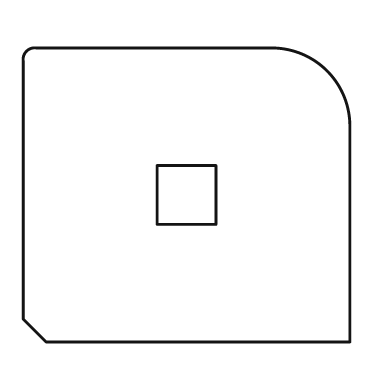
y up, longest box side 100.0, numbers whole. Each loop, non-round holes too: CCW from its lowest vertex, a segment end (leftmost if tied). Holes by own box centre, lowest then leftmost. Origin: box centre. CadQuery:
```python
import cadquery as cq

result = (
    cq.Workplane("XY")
    .moveTo(-43.0, -45.0)
    .lineTo(50.0, -45.0)
    .lineTo(50.0, 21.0)
    .threePointArc((43.0, 38.0), (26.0, 45.0))
    .lineTo(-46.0, 45.0)
    .threePointArc((-49.0, 44.0), (-50.0, 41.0))
    .lineTo(-50.0, -38.0)
    .close()
    .moveTo(-9.0, -9.0)
    .lineTo(9.0, -9.0)
    .lineTo(9.0, 9.0)
    .lineTo(-9.0, 9.0)
    .close()
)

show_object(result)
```